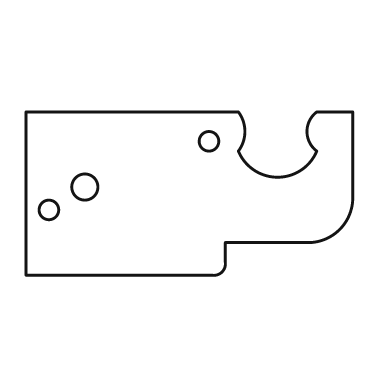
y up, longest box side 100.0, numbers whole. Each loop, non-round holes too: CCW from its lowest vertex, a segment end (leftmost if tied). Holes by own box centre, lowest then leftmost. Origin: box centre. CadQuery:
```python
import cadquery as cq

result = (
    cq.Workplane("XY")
    .moveTo(-50.0, -25.0)
    .lineTo(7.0, -25.0)
    .threePointArc((10.0, -24.0), (11.0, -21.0))
    .lineTo(11.0, -15.0)
    .lineTo(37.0, -15.0)
    .threePointArc((46.0, -11.0), (50.0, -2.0))
    .lineTo(50.0, 25.0)
    .lineTo(39.0, 25.0)
    .threePointArc((36.0, 19.0), (39.0, 13.0))
    .threePointArc((27.0, 5.0), (15.0, 13.0))
    .threePointArc((17.0, 19.0), (15.0, 25.0))
    .lineTo(-50.0, 25.0)
    .close()
    .moveTo(-43.0, -5.0)
    .circle(3.0)
    .moveTo(-32.0, 2.0)
    .circle(4.0)
    .moveTo(6.0, 16.0)
    .circle(3.0)
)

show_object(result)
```